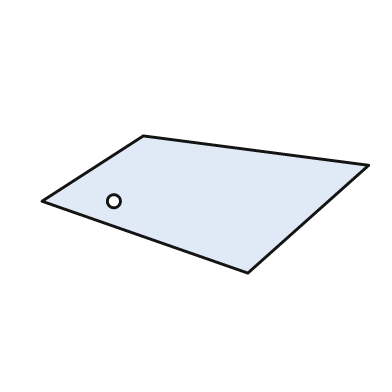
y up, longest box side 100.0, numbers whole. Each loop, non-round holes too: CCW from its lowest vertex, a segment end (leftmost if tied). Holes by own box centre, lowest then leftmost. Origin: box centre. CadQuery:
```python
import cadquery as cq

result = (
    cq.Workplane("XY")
    .moveTo(13.0, -21.0)
    .lineTo(50.0, 12.0)
    .lineTo(-19.0, 21.0)
    .lineTo(-50.0, 1.0)
    .close()
    .moveTo(-28.0, 1.0)
    .circle(2.0)
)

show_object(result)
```